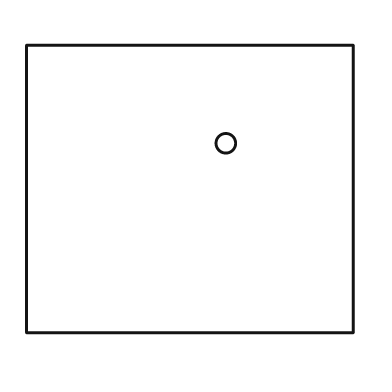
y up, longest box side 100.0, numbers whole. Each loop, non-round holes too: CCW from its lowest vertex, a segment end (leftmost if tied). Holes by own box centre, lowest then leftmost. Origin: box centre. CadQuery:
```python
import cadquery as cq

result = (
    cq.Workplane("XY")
    .moveTo(-50.0, -44.0)
    .lineTo(50.0, -44.0)
    .lineTo(50.0, 44.0)
    .lineTo(-50.0, 44.0)
    .close()
    .moveTo(11.0, 14.0)
    .circle(3.0)
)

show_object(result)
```